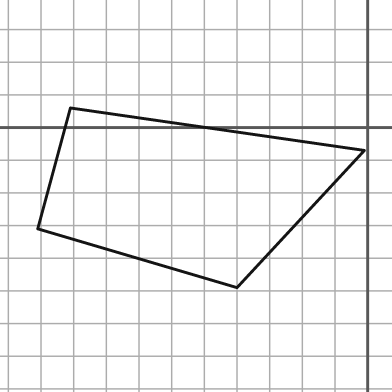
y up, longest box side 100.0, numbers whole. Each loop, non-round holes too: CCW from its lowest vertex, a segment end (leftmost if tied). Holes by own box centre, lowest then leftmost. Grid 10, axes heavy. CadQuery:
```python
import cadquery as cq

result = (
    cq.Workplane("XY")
    .moveTo(-40.0, -49.0)
    .lineTo(-1.0, -7.0)
    .lineTo(-91.0, 6.0)
    .lineTo(-101.0, -31.0)
    .close()
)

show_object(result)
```